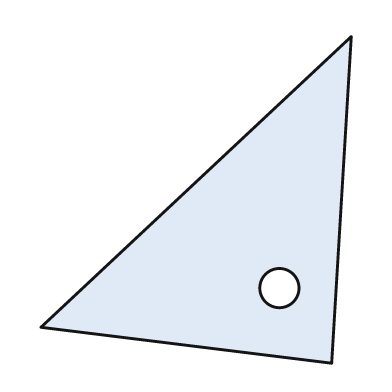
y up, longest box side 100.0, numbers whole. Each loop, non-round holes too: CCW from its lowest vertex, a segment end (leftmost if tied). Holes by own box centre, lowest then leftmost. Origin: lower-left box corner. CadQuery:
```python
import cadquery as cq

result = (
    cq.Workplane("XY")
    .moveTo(89.0, 0.0)
    .lineTo(95.0, 100.0)
    .lineTo(0.0, 11.0)
    .close()
    .moveTo(73.0, 23.0)
    .circle(6.0)
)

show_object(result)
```